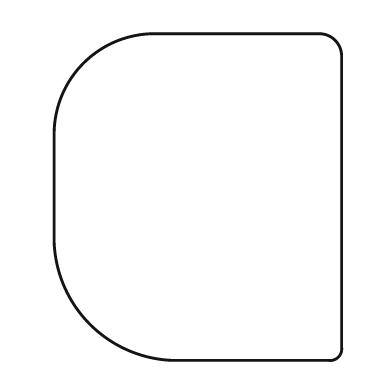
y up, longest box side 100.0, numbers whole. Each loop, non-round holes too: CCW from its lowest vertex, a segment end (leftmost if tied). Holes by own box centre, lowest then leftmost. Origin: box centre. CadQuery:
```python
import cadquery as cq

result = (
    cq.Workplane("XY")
    .moveTo(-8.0, -50.0)
    .lineTo(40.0, -50.0)
    .threePointArc((43.0, -49.0), (44.0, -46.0))
    .lineTo(44.0, 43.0)
    .threePointArc((42.0, 48.0), (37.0, 50.0))
    .lineTo(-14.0, 50.0)
    .threePointArc((-35.0, 41.0), (-44.0, 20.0))
    .lineTo(-44.0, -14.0)
    .threePointArc((-33.0, -39.0), (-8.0, -50.0))
    .close()
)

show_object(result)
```